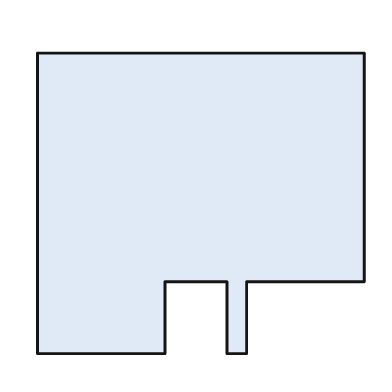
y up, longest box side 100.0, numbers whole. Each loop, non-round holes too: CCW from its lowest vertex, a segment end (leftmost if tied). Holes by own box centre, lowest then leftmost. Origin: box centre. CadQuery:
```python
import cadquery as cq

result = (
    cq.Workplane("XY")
    .moveTo(-50.0, -46.0)
    .lineTo(-11.0, -46.0)
    .lineTo(-11.0, -24.0)
    .lineTo(8.0, -24.0)
    .lineTo(8.0, -46.0)
    .lineTo(14.0, -46.0)
    .lineTo(14.0, -24.0)
    .lineTo(50.0, -24.0)
    .lineTo(50.0, 46.0)
    .lineTo(-50.0, 46.0)
    .close()
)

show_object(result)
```